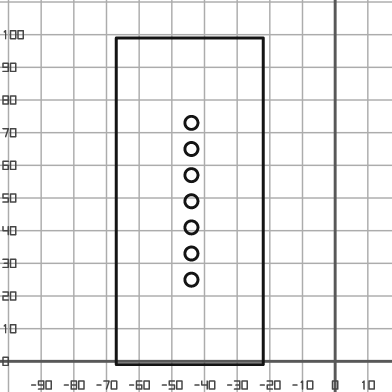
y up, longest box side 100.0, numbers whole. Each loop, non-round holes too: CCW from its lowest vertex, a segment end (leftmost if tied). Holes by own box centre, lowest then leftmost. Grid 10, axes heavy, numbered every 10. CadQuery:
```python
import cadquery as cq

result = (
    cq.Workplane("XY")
    .moveTo(-67.0, -1.0)
    .lineTo(-22.0, -1.0)
    .lineTo(-22.0, 99.0)
    .lineTo(-67.0, 99.0)
    .close()
    .moveTo(-44.0, 25.0)
    .circle(2.0)
    .moveTo(-44.0, 33.0)
    .circle(2.0)
    .moveTo(-44.0, 41.0)
    .circle(2.0)
    .moveTo(-44.0, 49.0)
    .circle(2.0)
    .moveTo(-44.0, 57.0)
    .circle(2.0)
    .moveTo(-44.0, 65.0)
    .circle(2.0)
    .moveTo(-44.0, 73.0)
    .circle(2.0)
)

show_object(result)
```